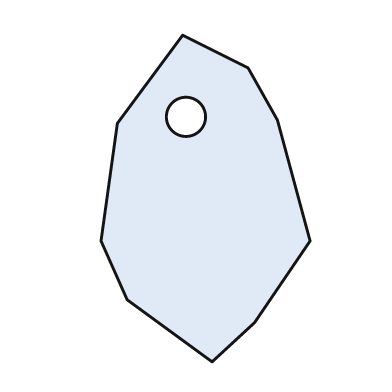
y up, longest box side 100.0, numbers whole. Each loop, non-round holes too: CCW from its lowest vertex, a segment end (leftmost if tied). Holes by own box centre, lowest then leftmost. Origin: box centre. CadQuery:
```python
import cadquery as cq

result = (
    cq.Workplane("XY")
    .moveTo(2.0, -50.0)
    .lineTo(15.0, -38.0)
    .lineTo(32.0, -13.0)
    .lineTo(22.0, 24.0)
    .lineTo(13.0, 40.0)
    .lineTo(-7.0, 50.0)
    .lineTo(-27.0, 23.0)
    .lineTo(-32.0, -13.0)
    .lineTo(-24.0, -31.0)
    .close()
    .moveTo(-6.0, 25.0)
    .circle(6.0)
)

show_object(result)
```